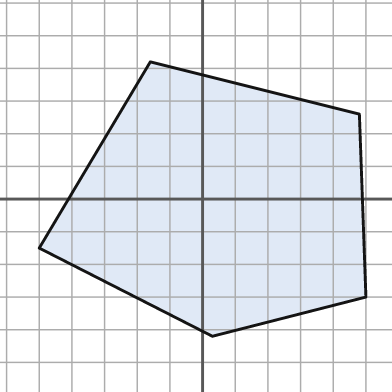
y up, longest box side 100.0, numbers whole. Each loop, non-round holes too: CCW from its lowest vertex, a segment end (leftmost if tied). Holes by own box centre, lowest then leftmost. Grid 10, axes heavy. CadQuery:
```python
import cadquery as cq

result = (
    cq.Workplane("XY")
    .moveTo(3.0, -42.0)
    .lineTo(50.0, -30.0)
    .lineTo(48.0, 26.0)
    .lineTo(-16.0, 42.0)
    .lineTo(-50.0, -15.0)
    .close()
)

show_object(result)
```